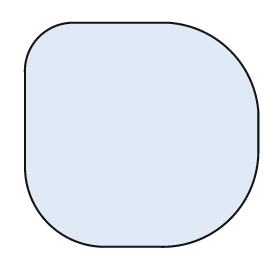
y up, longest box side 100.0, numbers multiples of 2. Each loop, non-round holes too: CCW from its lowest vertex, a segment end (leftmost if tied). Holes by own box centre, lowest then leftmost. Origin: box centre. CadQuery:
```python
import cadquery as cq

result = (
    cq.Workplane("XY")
    .moveTo(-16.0, -48.0)
    .lineTo(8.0, -48.0)
    .threePointArc((38.0, -36.0), (50.0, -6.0))
    .lineTo(50.0, 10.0)
    .threePointArc((38.0, 36.0), (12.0, 48.0))
    .lineTo(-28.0, 48.0)
    .threePointArc((-44.0, 42.0), (-50.0, 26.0))
    .lineTo(-50.0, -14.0)
    .threePointArc((-40.0, -38.0), (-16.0, -48.0))
    .close()
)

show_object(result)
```